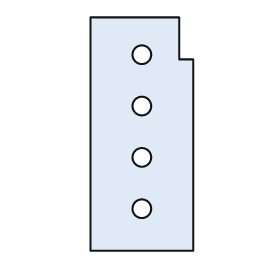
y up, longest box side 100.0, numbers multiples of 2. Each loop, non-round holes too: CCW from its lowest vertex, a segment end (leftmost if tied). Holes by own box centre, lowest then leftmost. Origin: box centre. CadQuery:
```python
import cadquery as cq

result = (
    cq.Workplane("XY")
    .moveTo(-22.0, -50.0)
    .lineTo(22.0, -50.0)
    .lineTo(22.0, 32.0)
    .lineTo(16.0, 32.0)
    .lineTo(16.0, 50.0)
    .lineTo(-22.0, 50.0)
    .close()
    .moveTo(0.0, -32.0)
    .circle(4.0)
    .moveTo(0.0, -10.0)
    .circle(4.0)
    .moveTo(0.0, 12.0)
    .circle(4.0)
    .moveTo(0.0, 34.0)
    .circle(4.0)
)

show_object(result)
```